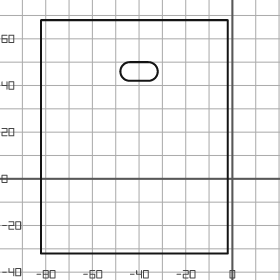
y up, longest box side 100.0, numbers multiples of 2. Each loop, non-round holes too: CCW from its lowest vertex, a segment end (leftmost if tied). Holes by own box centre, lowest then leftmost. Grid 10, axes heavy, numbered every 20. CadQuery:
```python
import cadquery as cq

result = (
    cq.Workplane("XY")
    .moveTo(-82.0, -32.0)
    .lineTo(-2.0, -32.0)
    .lineTo(-2.0, 68.0)
    .lineTo(-82.0, 68.0)
    .close()
    .moveTo(-44.0, 42.0)
    .lineTo(-36.0, 42.0)
    .threePointArc((-32.0, 46.0), (-36.0, 50.0))
    .lineTo(-44.0, 50.0)
    .threePointArc((-48.0, 46.0), (-44.0, 42.0))
    .close()
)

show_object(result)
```